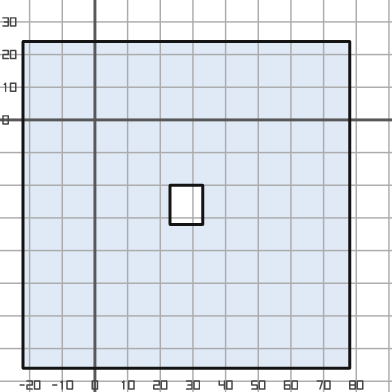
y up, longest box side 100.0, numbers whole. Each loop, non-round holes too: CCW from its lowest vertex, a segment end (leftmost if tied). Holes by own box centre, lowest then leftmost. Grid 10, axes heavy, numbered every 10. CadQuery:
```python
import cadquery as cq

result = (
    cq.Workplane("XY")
    .moveTo(-22.0, -76.0)
    .lineTo(78.0, -76.0)
    .lineTo(78.0, 24.0)
    .lineTo(-22.0, 24.0)
    .close()
    .moveTo(23.0, -32.0)
    .lineTo(33.0, -32.0)
    .lineTo(33.0, -20.0)
    .lineTo(23.0, -20.0)
    .close()
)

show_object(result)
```